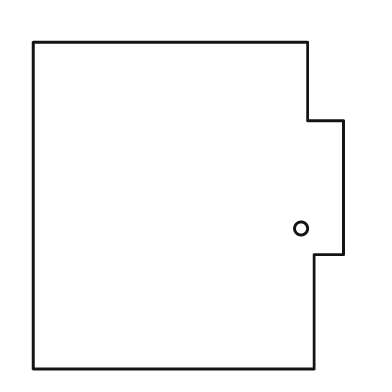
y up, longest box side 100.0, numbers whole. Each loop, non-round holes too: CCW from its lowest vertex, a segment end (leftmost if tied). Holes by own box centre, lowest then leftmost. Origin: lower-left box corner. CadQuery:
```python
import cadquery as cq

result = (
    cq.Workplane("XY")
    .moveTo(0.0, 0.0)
    .lineTo(86.0, 0.0)
    .lineTo(86.0, 35.0)
    .lineTo(95.0, 35.0)
    .lineTo(95.0, 76.0)
    .lineTo(84.0, 76.0)
    .lineTo(84.0, 100.0)
    .lineTo(0.0, 100.0)
    .close()
    .moveTo(82.0, 43.0)
    .circle(2.0)
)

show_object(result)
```